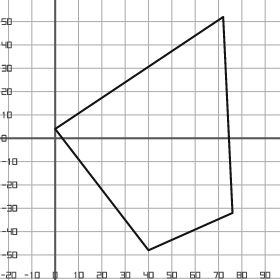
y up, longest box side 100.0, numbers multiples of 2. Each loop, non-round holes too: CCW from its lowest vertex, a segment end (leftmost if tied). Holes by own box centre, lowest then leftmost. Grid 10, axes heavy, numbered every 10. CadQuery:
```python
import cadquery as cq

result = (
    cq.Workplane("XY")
    .moveTo(40.0, -48.0)
    .lineTo(76.0, -32.0)
    .lineTo(72.0, 52.0)
    .lineTo(0.0, 4.0)
    .close()
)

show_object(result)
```